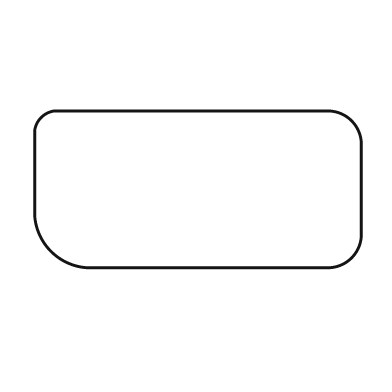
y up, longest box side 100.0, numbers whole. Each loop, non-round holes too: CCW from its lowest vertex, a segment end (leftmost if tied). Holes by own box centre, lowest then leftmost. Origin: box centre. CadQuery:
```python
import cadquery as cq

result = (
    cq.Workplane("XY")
    .moveTo(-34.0, -24.0)
    .lineTo(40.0, -24.0)
    .threePointArc((47.0, -21.0), (50.0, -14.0))
    .lineTo(50.0, 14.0)
    .threePointArc((47.0, 21.0), (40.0, 24.0))
    .lineTo(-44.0, 24.0)
    .threePointArc((-48.0, 22.0), (-50.0, 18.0))
    .lineTo(-50.0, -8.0)
    .threePointArc((-45.0, -19.0), (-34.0, -24.0))
    .close()
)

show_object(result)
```